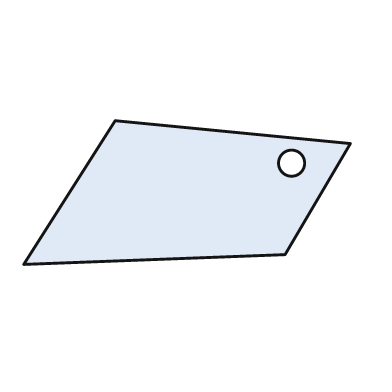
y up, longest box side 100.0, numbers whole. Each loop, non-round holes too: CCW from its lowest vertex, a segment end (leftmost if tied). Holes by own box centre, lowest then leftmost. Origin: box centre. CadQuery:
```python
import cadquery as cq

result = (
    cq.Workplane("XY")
    .moveTo(-50.0, -22.0)
    .lineTo(30.0, -19.0)
    .lineTo(50.0, 15.0)
    .lineTo(-22.0, 22.0)
    .close()
    .moveTo(32.0, 9.0)
    .circle(4.0)
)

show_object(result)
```